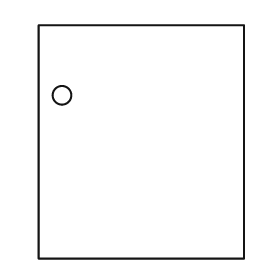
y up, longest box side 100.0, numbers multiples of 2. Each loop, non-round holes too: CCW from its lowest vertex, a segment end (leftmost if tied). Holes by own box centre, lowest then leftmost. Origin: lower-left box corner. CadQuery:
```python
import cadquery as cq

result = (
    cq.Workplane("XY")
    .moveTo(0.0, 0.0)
    .lineTo(88.0, 0.0)
    .lineTo(88.0, 100.0)
    .lineTo(0.0, 100.0)
    .close()
    .moveTo(10.0, 70.0)
    .circle(4.0)
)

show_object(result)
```